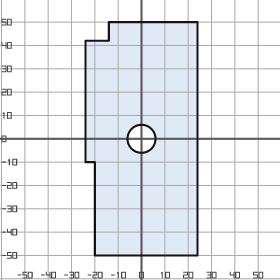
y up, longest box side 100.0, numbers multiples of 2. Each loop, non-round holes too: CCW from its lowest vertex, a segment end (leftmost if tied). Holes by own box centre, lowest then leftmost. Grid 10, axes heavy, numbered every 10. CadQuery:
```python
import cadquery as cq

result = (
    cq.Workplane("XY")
    .moveTo(-20.0, -50.0)
    .lineTo(24.0, -50.0)
    .lineTo(24.0, 50.0)
    .lineTo(-14.0, 50.0)
    .lineTo(-14.0, 42.0)
    .lineTo(-24.0, 42.0)
    .lineTo(-24.0, -10.0)
    .lineTo(-20.0, -10.0)
    .close()
    .moveTo(0.0, 0.0)
    .circle(6.0)
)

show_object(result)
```